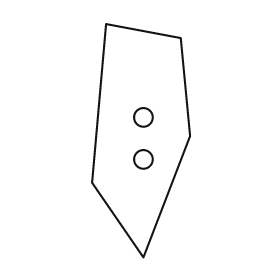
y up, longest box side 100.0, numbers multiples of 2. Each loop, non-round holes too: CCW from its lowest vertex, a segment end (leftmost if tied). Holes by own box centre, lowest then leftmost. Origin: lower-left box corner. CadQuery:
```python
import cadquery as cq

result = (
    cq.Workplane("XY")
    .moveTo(22.0, 0.0)
    .lineTo(42.0, 52.0)
    .lineTo(38.0, 94.0)
    .lineTo(6.0, 100.0)
    .lineTo(0.0, 32.0)
    .close()
    .moveTo(22.0, 42.0)
    .circle(4.0)
    .moveTo(22.0, 60.0)
    .circle(4.0)
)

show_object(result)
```